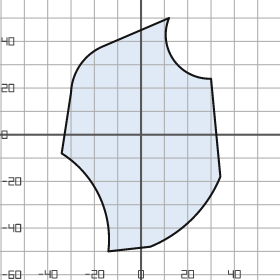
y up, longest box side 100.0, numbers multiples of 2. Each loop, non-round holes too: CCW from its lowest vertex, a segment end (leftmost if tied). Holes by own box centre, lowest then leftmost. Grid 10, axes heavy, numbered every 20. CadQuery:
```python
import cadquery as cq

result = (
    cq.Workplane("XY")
    .moveTo(-14.0, -50.0)
    .lineTo(4.0, -48.0)
    .threePointArc((22.0, -36.0), (34.0, -18.0))
    .lineTo(30.0, 24.0)
    .threePointArc((14.0, 32.0), (12.0, 50.0))
    .lineTo(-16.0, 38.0)
    .threePointArc((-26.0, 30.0), (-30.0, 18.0))
    .lineTo(-34.0, -8.0)
    .threePointArc((-18.0, -26.0), (-14.0, -50.0))
    .close()
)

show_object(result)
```